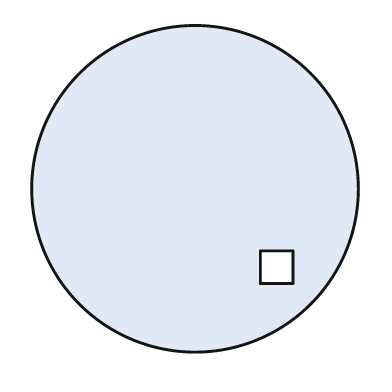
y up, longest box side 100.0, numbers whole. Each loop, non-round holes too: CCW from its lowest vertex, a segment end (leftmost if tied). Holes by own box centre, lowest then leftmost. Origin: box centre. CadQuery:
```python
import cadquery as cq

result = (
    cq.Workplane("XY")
    .moveTo(0.0, 0.0)
    .circle(50.0)
    .moveTo(20.0, -29.0)
    .lineTo(30.0, -29.0)
    .lineTo(30.0, -19.0)
    .lineTo(20.0, -19.0)
    .close()
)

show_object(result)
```